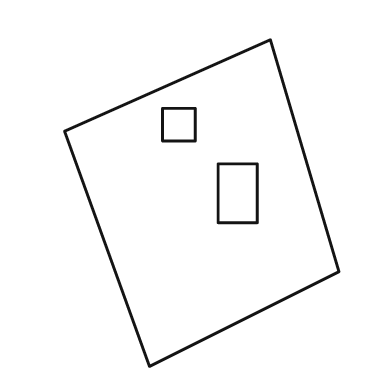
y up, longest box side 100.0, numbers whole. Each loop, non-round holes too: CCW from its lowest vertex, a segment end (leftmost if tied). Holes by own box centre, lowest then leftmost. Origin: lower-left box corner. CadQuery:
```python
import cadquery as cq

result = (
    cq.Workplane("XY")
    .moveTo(26.0, 0.0)
    .lineTo(84.0, 29.0)
    .lineTo(63.0, 100.0)
    .lineTo(0.0, 72.0)
    .close()
    .moveTo(47.0, 44.0)
    .lineTo(59.0, 44.0)
    .lineTo(59.0, 62.0)
    .lineTo(47.0, 62.0)
    .close()
    .moveTo(30.0, 69.0)
    .lineTo(40.0, 69.0)
    .lineTo(40.0, 79.0)
    .lineTo(30.0, 79.0)
    .close()
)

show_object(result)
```